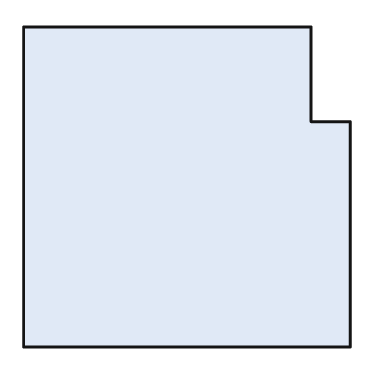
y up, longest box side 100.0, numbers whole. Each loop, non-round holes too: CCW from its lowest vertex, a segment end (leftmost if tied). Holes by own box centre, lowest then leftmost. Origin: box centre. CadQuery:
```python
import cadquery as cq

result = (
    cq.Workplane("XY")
    .moveTo(-50.0, -49.0)
    .lineTo(50.0, -49.0)
    .lineTo(50.0, 20.0)
    .lineTo(38.0, 20.0)
    .lineTo(38.0, 49.0)
    .lineTo(-50.0, 49.0)
    .close()
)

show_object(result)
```